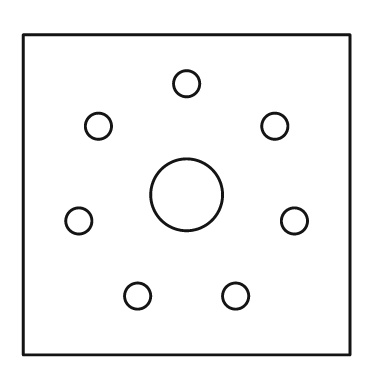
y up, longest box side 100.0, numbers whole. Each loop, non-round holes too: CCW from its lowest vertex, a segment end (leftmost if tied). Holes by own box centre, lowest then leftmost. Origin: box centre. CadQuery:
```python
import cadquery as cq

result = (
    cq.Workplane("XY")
    .moveTo(-50.0, -49.0)
    .lineTo(50.0, -49.0)
    .lineTo(50.0, 49.0)
    .lineTo(-50.0, 49.0)
    .close()
    .moveTo(-15.0, -31.0)
    .circle(4.0)
    .moveTo(15.0, -31.0)
    .circle(4.0)
    .moveTo(-33.0, -8.0)
    .circle(4.0)
    .moveTo(33.0, -8.0)
    .circle(4.0)
    .moveTo(0.0, 0.0)
    .circle(11.0)
    .moveTo(-27.0, 21.0)
    .circle(4.0)
    .moveTo(27.0, 21.0)
    .circle(4.0)
    .moveTo(0.0, 34.0)
    .circle(4.0)
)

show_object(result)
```